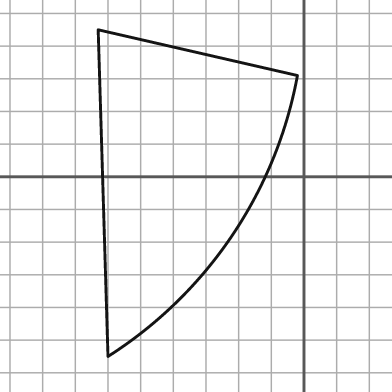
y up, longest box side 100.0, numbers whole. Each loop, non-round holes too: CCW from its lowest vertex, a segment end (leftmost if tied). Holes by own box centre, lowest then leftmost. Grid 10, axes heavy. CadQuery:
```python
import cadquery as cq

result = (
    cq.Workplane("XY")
    .moveTo(-60.0, -55.0)
    .threePointArc((-22.0, -18.0), (-2.0, 31.0))
    .lineTo(-63.0, 45.0)
    .close()
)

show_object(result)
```